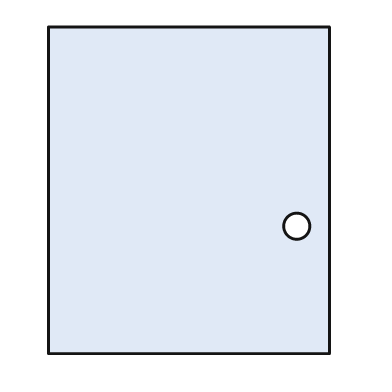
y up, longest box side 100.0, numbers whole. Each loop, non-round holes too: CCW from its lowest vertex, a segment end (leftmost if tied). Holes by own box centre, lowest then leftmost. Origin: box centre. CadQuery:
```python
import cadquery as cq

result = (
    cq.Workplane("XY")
    .moveTo(-43.0, -50.0)
    .lineTo(43.0, -50.0)
    .lineTo(43.0, 50.0)
    .lineTo(-43.0, 50.0)
    .close()
    .moveTo(33.0, -11.0)
    .circle(4.0)
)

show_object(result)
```